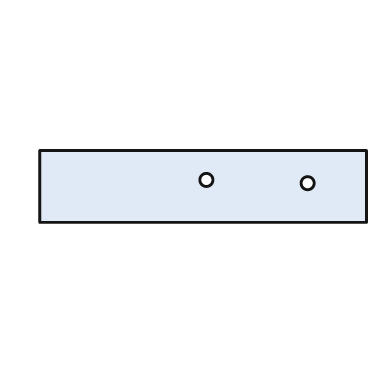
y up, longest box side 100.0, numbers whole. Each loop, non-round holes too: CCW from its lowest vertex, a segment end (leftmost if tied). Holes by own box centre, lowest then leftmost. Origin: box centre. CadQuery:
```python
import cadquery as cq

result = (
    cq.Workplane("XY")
    .moveTo(-50.0, -11.0)
    .lineTo(50.0, -11.0)
    .lineTo(50.0, 11.0)
    .lineTo(-50.0, 11.0)
    .close()
    .moveTo(32.0, 1.0)
    .circle(2.0)
    .moveTo(1.0, 2.0)
    .circle(2.0)
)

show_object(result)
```